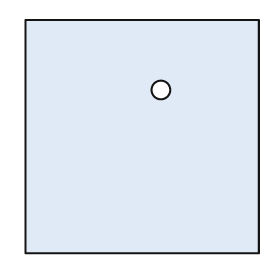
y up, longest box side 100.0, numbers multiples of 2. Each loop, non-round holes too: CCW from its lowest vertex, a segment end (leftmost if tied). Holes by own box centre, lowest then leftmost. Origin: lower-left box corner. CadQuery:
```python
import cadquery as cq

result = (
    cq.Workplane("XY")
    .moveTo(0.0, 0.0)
    .lineTo(100.0, 0.0)
    .lineTo(100.0, 100.0)
    .lineTo(0.0, 100.0)
    .close()
    .moveTo(58.0, 70.0)
    .circle(4.0)
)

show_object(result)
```